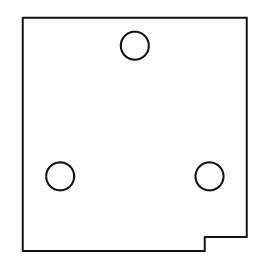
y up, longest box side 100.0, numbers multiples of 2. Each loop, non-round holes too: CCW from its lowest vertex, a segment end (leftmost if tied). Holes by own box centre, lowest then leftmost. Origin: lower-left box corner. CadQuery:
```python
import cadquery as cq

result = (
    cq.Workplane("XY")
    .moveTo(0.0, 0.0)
    .lineTo(78.0, 0.0)
    .lineTo(78.0, 6.0)
    .lineTo(96.0, 6.0)
    .lineTo(96.0, 100.0)
    .lineTo(0.0, 100.0)
    .close()
    .moveTo(16.0, 32.0)
    .circle(6.0)
    .moveTo(80.0, 32.0)
    .circle(6.0)
    .moveTo(48.0, 88.0)
    .circle(6.0)
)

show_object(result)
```